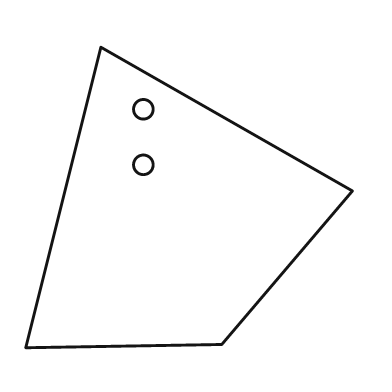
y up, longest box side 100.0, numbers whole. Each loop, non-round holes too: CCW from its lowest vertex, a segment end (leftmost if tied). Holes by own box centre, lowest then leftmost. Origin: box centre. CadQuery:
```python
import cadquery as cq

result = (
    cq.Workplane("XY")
    .moveTo(-50.0, -46.0)
    .lineTo(10.0, -45.0)
    .lineTo(50.0, 2.0)
    .lineTo(-27.0, 46.0)
    .close()
    .moveTo(-14.0, 10.0)
    .circle(3.0)
    .moveTo(-14.0, 27.0)
    .circle(3.0)
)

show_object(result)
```